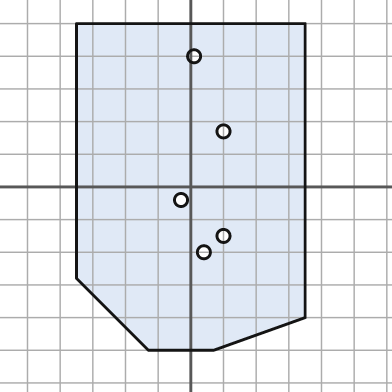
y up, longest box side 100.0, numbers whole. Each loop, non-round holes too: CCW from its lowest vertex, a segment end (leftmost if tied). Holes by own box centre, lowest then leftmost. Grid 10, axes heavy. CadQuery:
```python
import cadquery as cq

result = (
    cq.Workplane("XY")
    .moveTo(-13.0, -50.0)
    .lineTo(7.0, -50.0)
    .lineTo(35.0, -40.0)
    .lineTo(35.0, 50.0)
    .lineTo(-35.0, 50.0)
    .lineTo(-35.0, -28.0)
    .close()
    .moveTo(4.0, -20.0)
    .circle(2.0)
    .moveTo(10.0, -15.0)
    .circle(2.0)
    .moveTo(-3.0, -4.0)
    .circle(2.0)
    .moveTo(10.0, 17.0)
    .circle(2.0)
    .moveTo(1.0, 40.0)
    .circle(2.0)
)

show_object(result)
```